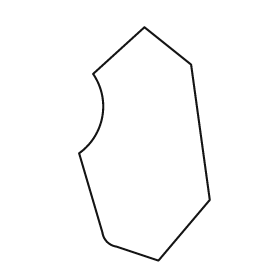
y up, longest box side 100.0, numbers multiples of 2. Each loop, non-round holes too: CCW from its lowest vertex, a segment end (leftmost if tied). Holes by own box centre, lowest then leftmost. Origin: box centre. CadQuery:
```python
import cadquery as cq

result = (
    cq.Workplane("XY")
    .moveTo(6.0, -50.0)
    .lineTo(28.0, -24.0)
    .lineTo(20.0, 34.0)
    .lineTo(0.0, 50.0)
    .lineTo(-22.0, 30.0)
    .threePointArc((-18.0, 12.0), (-28.0, -4.0))
    .lineTo(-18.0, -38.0)
    .threePointArc((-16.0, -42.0), (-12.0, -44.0))
    .close()
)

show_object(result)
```